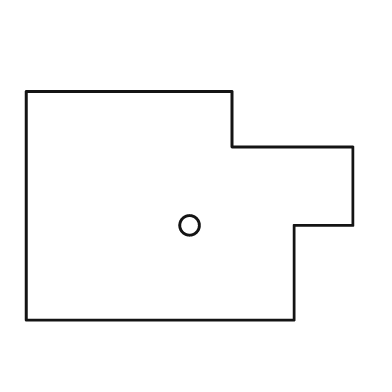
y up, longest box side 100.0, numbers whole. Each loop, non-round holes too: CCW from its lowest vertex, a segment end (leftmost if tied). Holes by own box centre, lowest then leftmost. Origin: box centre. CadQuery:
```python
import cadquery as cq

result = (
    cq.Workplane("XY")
    .moveTo(-50.0, -35.0)
    .lineTo(32.0, -35.0)
    .lineTo(32.0, -6.0)
    .lineTo(50.0, -6.0)
    .lineTo(50.0, 18.0)
    .lineTo(13.0, 18.0)
    .lineTo(13.0, 35.0)
    .lineTo(-50.0, 35.0)
    .close()
    .moveTo(0.0, -6.0)
    .circle(3.0)
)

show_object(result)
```